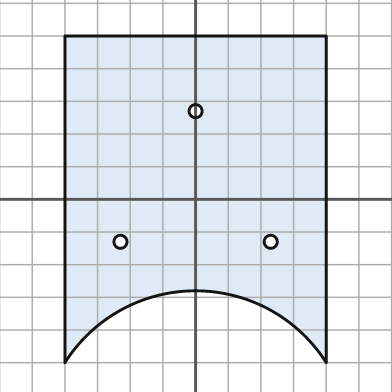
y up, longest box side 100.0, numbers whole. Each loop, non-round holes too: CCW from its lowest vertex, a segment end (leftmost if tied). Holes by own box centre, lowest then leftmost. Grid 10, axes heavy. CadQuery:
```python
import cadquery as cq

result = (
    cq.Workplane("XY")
    .moveTo(-40.0, -50.0)
    .threePointArc((0.0, -28.0), (40.0, -50.0))
    .lineTo(40.0, 50.0)
    .lineTo(-40.0, 50.0)
    .close()
    .moveTo(-23.0, -13.0)
    .circle(2.0)
    .moveTo(23.0, -13.0)
    .circle(2.0)
    .moveTo(0.0, 27.0)
    .circle(2.0)
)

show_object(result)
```